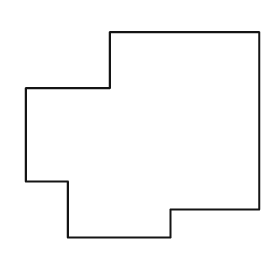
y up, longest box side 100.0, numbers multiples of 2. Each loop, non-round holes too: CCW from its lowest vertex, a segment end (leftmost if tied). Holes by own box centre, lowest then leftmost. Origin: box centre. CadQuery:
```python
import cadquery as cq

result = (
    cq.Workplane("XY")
    .moveTo(-32.0, -44.0)
    .lineTo(12.0, -44.0)
    .lineTo(12.0, -32.0)
    .lineTo(50.0, -32.0)
    .lineTo(50.0, 44.0)
    .lineTo(-14.0, 44.0)
    .lineTo(-14.0, 20.0)
    .lineTo(-50.0, 20.0)
    .lineTo(-50.0, -20.0)
    .lineTo(-32.0, -20.0)
    .close()
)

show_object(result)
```